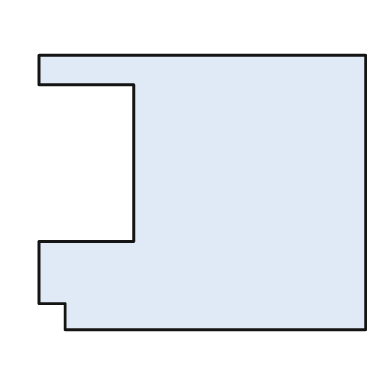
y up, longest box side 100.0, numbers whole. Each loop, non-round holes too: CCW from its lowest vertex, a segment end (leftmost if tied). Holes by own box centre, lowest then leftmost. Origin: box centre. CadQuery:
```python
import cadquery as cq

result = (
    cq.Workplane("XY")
    .moveTo(-42.0, -42.0)
    .lineTo(50.0, -42.0)
    .lineTo(50.0, 42.0)
    .lineTo(-50.0, 42.0)
    .lineTo(-50.0, 33.0)
    .lineTo(-21.0, 33.0)
    .lineTo(-21.0, -15.0)
    .lineTo(-50.0, -15.0)
    .lineTo(-50.0, -34.0)
    .lineTo(-42.0, -34.0)
    .close()
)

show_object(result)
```